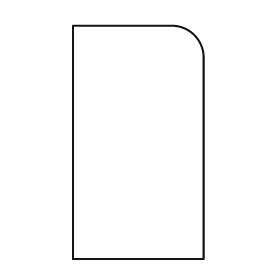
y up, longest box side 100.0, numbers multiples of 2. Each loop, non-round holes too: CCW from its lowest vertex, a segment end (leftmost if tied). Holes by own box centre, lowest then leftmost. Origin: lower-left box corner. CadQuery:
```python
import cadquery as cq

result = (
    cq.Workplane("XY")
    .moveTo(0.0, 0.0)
    .lineTo(56.0, 0.0)
    .lineTo(56.0, 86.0)
    .threePointArc((52.0, 96.0), (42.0, 100.0))
    .lineTo(0.0, 100.0)
    .close()
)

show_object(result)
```